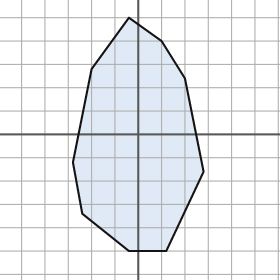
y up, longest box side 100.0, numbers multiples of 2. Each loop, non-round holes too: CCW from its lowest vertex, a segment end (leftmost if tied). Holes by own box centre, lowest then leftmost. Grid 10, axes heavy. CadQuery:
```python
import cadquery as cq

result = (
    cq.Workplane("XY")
    .moveTo(-4.0, -50.0)
    .lineTo(12.0, -50.0)
    .lineTo(28.0, -16.0)
    .lineTo(20.0, 24.0)
    .lineTo(10.0, 40.0)
    .lineTo(-4.0, 50.0)
    .lineTo(-20.0, 28.0)
    .lineTo(-28.0, -12.0)
    .lineTo(-24.0, -34.0)
    .close()
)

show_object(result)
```